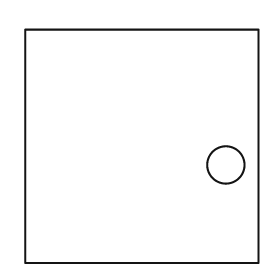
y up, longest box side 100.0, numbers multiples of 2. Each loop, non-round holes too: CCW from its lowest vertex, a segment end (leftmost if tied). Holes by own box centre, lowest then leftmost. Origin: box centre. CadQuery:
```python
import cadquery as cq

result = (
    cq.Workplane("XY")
    .moveTo(-50.0, -50.0)
    .lineTo(50.0, -50.0)
    .lineTo(50.0, 50.0)
    .lineTo(-50.0, 50.0)
    .close()
    .moveTo(36.0, -8.0)
    .circle(8.0)
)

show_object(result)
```